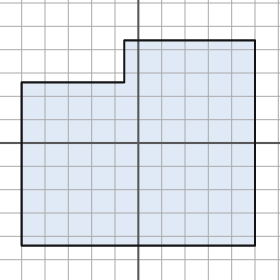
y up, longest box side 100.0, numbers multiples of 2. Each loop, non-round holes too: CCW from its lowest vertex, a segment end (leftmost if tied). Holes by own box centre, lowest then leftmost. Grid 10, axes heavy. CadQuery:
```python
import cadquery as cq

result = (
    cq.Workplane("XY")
    .moveTo(-50.0, -44.0)
    .lineTo(50.0, -44.0)
    .lineTo(50.0, 44.0)
    .lineTo(-6.0, 44.0)
    .lineTo(-6.0, 26.0)
    .lineTo(-50.0, 26.0)
    .close()
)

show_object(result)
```